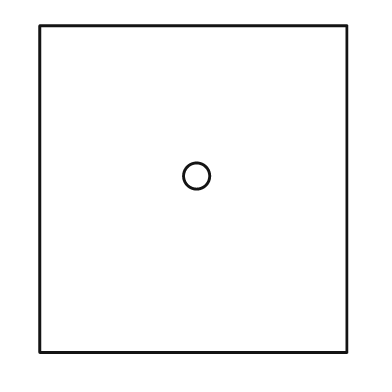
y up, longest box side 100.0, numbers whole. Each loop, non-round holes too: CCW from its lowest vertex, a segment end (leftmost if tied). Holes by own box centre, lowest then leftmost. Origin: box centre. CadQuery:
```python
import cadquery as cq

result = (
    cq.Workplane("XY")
    .moveTo(-47.0, -50.0)
    .lineTo(47.0, -50.0)
    .lineTo(47.0, 50.0)
    .lineTo(-47.0, 50.0)
    .close()
    .moveTo(1.0, 4.0)
    .circle(4.0)
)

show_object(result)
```